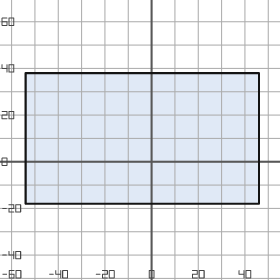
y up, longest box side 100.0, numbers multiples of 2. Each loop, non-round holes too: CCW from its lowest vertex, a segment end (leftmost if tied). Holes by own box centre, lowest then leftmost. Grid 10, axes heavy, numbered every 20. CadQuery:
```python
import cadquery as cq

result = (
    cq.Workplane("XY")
    .moveTo(-54.0, -18.0)
    .lineTo(46.0, -18.0)
    .lineTo(46.0, 38.0)
    .lineTo(-54.0, 38.0)
    .close()
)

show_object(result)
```